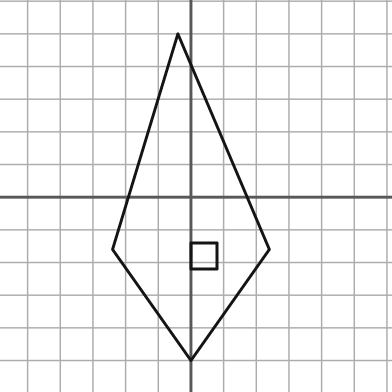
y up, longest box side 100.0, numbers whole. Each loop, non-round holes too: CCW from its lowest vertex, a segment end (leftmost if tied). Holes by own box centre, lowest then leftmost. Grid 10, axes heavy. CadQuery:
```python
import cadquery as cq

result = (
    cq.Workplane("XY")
    .moveTo(0.0, -50.0)
    .lineTo(24.0, -16.0)
    .lineTo(-4.0, 50.0)
    .lineTo(-24.0, -16.0)
    .close()
    .moveTo(0.0, -22.0)
    .lineTo(8.0, -22.0)
    .lineTo(8.0, -14.0)
    .lineTo(0.0, -14.0)
    .close()
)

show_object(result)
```